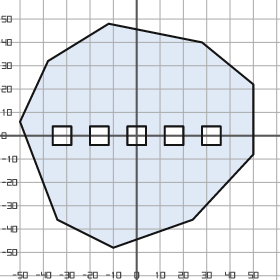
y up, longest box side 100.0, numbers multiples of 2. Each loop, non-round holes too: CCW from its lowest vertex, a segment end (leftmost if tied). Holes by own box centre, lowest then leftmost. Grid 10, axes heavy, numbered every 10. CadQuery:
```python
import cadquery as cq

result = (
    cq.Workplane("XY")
    .moveTo(-10.0, -48.0)
    .lineTo(24.0, -36.0)
    .lineTo(50.0, -8.0)
    .lineTo(50.0, 22.0)
    .lineTo(28.0, 40.0)
    .lineTo(-12.0, 48.0)
    .lineTo(-38.0, 32.0)
    .lineTo(-50.0, 6.0)
    .lineTo(-34.0, -36.0)
    .close()
    .moveTo(-36.0, -4.0)
    .lineTo(-28.0, -4.0)
    .lineTo(-28.0, 4.0)
    .lineTo(-36.0, 4.0)
    .close()
    .moveTo(-20.0, -4.0)
    .lineTo(-12.0, -4.0)
    .lineTo(-12.0, 4.0)
    .lineTo(-20.0, 4.0)
    .close()
    .moveTo(-4.0, -4.0)
    .lineTo(4.0, -4.0)
    .lineTo(4.0, 4.0)
    .lineTo(-4.0, 4.0)
    .close()
    .moveTo(12.0, -4.0)
    .lineTo(20.0, -4.0)
    .lineTo(20.0, 4.0)
    .lineTo(12.0, 4.0)
    .close()
    .moveTo(28.0, -4.0)
    .lineTo(36.0, -4.0)
    .lineTo(36.0, 4.0)
    .lineTo(28.0, 4.0)
    .close()
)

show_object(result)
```